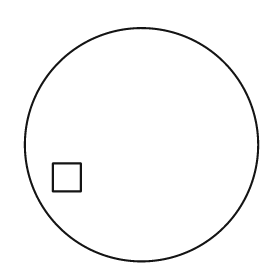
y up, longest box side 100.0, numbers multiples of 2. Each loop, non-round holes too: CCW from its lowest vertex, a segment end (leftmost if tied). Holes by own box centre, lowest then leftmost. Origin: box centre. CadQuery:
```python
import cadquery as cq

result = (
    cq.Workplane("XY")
    .moveTo(0.0, 0.0)
    .circle(50.0)
    .moveTo(-38.0, -20.0)
    .lineTo(-26.0, -20.0)
    .lineTo(-26.0, -8.0)
    .lineTo(-38.0, -8.0)
    .close()
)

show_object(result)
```